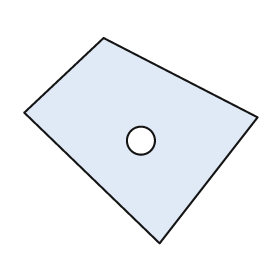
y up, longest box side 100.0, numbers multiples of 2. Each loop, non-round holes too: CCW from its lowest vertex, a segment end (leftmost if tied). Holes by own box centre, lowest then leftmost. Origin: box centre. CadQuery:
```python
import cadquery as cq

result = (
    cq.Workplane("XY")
    .moveTo(8.0, -44.0)
    .lineTo(50.0, 10.0)
    .lineTo(-16.0, 44.0)
    .lineTo(-50.0, 12.0)
    .close()
    .moveTo(0.0, 0.0)
    .circle(6.0)
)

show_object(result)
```